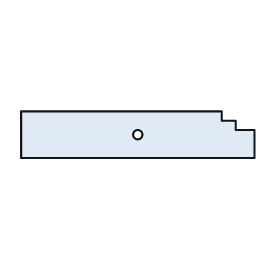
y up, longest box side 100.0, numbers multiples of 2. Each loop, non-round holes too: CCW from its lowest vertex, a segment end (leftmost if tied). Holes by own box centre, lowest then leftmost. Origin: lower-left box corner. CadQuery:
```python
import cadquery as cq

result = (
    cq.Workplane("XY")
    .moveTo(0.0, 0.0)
    .lineTo(100.0, 0.0)
    .lineTo(100.0, 12.0)
    .lineTo(92.0, 12.0)
    .lineTo(92.0, 16.0)
    .lineTo(86.0, 16.0)
    .lineTo(86.0, 20.0)
    .lineTo(0.0, 20.0)
    .close()
    .moveTo(50.0, 10.0)
    .circle(2.0)
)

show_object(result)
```